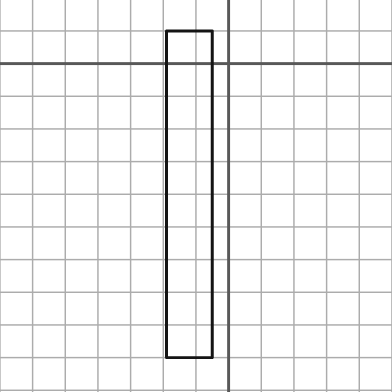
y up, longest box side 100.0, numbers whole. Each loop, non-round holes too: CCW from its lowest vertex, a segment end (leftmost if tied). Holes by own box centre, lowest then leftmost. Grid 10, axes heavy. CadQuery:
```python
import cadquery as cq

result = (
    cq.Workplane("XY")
    .moveTo(-19.0, -90.0)
    .lineTo(-5.0, -90.0)
    .lineTo(-5.0, 10.0)
    .lineTo(-19.0, 10.0)
    .close()
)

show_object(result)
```